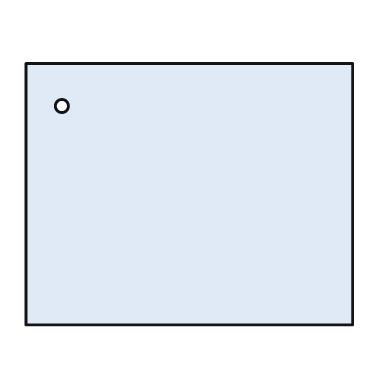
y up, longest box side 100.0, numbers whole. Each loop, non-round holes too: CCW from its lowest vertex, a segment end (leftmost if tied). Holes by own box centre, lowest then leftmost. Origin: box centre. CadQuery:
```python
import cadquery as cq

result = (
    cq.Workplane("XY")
    .moveTo(-50.0, -40.0)
    .lineTo(50.0, -40.0)
    .lineTo(50.0, 40.0)
    .lineTo(-50.0, 40.0)
    .close()
    .moveTo(-39.0, 27.0)
    .circle(2.0)
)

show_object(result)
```